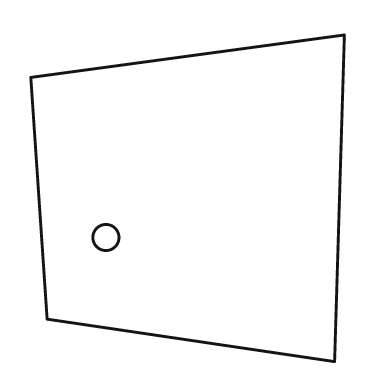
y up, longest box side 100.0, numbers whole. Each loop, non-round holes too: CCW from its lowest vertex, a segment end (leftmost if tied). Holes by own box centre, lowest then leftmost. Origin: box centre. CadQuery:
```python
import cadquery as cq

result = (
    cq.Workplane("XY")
    .moveTo(45.0, -50.0)
    .lineTo(48.0, 50.0)
    .lineTo(-48.0, 37.0)
    .lineTo(-43.0, -37.0)
    .close()
    .moveTo(-25.0, -12.0)
    .circle(4.0)
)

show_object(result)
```